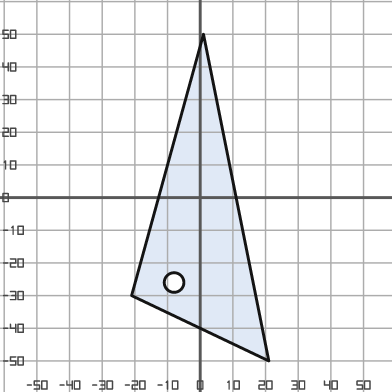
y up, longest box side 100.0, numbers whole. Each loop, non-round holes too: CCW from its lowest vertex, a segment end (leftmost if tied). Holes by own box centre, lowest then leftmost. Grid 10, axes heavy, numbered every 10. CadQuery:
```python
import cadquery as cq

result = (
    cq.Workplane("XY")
    .moveTo(21.0, -50.0)
    .lineTo(1.0, 50.0)
    .lineTo(-21.0, -30.0)
    .close()
    .moveTo(-8.0, -26.0)
    .circle(3.0)
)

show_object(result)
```